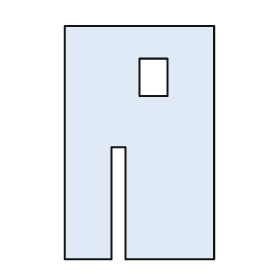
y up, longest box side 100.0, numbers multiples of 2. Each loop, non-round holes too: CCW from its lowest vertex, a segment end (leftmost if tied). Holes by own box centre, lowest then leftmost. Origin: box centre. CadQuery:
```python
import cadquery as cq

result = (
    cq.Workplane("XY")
    .moveTo(-32.0, -50.0)
    .lineTo(-12.0, -50.0)
    .lineTo(-12.0, -2.0)
    .lineTo(-6.0, -2.0)
    .lineTo(-6.0, -50.0)
    .lineTo(32.0, -50.0)
    .lineTo(32.0, 50.0)
    .lineTo(-32.0, 50.0)
    .close()
    .moveTo(0.0, 20.0)
    .lineTo(12.0, 20.0)
    .lineTo(12.0, 36.0)
    .lineTo(0.0, 36.0)
    .close()
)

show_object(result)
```